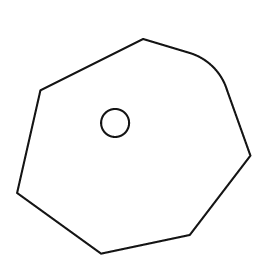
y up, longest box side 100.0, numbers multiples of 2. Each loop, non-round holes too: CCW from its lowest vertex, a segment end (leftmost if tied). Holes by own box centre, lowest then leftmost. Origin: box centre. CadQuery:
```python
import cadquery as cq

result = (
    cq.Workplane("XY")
    .moveTo(-14.0, -46.0)
    .lineTo(24.0, -38.0)
    .lineTo(50.0, -4.0)
    .lineTo(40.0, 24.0)
    .threePointArc((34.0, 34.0), (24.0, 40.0))
    .lineTo(4.0, 46.0)
    .lineTo(-40.0, 24.0)
    .lineTo(-50.0, -20.0)
    .close()
    .moveTo(-8.0, 10.0)
    .circle(6.0)
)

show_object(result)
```